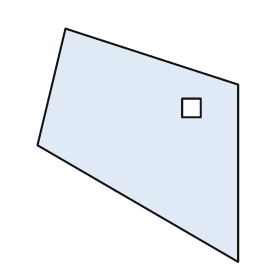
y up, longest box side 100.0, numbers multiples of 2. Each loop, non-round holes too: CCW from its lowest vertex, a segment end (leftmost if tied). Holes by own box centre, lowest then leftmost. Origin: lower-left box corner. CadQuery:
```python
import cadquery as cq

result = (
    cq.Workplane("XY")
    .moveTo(86.0, 0.0)
    .lineTo(86.0, 76.0)
    .lineTo(12.0, 100.0)
    .lineTo(0.0, 50.0)
    .close()
    .moveTo(62.0, 62.0)
    .lineTo(70.0, 62.0)
    .lineTo(70.0, 70.0)
    .lineTo(62.0, 70.0)
    .close()
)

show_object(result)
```